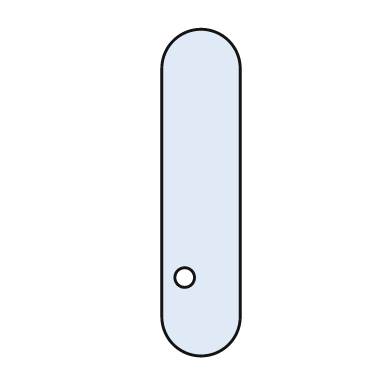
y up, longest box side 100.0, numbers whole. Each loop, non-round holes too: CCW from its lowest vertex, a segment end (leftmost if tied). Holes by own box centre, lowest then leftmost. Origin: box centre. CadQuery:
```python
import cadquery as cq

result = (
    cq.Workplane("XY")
    .moveTo(-12.0, -38.0)
    .threePointArc((0.0, -50.0), (12.0, -38.0))
    .lineTo(12.0, 38.0)
    .threePointArc((0.0, 50.0), (-12.0, 38.0))
    .close()
    .moveTo(-5.0, -26.0)
    .circle(3.0)
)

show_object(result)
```